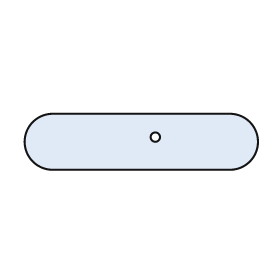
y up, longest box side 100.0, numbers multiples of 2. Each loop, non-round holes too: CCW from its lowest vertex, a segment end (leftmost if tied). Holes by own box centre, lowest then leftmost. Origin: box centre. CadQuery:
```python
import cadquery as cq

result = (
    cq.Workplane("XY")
    .moveTo(-38.0, -12.0)
    .lineTo(38.0, -12.0)
    .threePointArc((50.0, 0.0), (38.0, 12.0))
    .lineTo(-38.0, 12.0)
    .threePointArc((-50.0, 0.0), (-38.0, -12.0))
    .close()
    .moveTo(6.0, 2.0)
    .circle(2.0)
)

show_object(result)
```